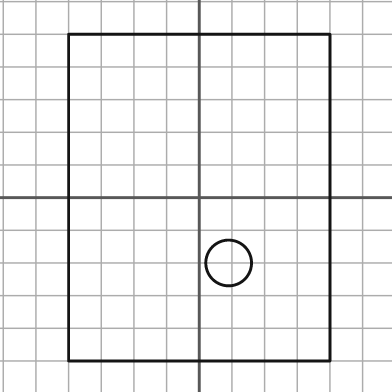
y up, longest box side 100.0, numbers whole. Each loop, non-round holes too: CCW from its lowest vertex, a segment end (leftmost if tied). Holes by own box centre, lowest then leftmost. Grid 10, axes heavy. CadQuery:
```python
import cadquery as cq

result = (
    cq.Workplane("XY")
    .moveTo(-40.0, -50.0)
    .lineTo(40.0, -50.0)
    .lineTo(40.0, 50.0)
    .lineTo(-40.0, 50.0)
    .close()
    .moveTo(9.0, -20.0)
    .circle(7.0)
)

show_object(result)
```